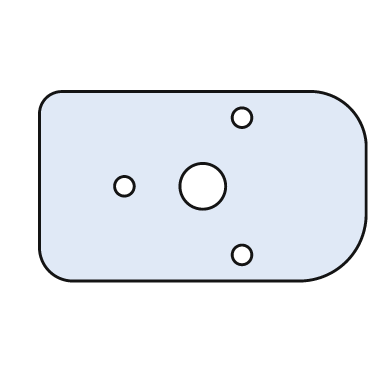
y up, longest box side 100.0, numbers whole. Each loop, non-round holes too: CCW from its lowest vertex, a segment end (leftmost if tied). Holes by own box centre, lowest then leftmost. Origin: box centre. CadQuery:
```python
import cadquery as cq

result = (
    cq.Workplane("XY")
    .moveTo(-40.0, -29.0)
    .lineTo(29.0, -29.0)
    .threePointArc((44.0, -23.0), (50.0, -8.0))
    .lineTo(50.0, 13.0)
    .threePointArc((45.0, 24.0), (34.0, 29.0))
    .lineTo(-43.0, 29.0)
    .threePointArc((-48.0, 27.0), (-50.0, 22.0))
    .lineTo(-50.0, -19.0)
    .threePointArc((-47.0, -26.0), (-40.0, -29.0))
    .close()
    .moveTo(12.0, -21.0)
    .circle(3.0)
    .moveTo(-24.0, 0.0)
    .circle(3.0)
    .moveTo(0.0, 0.0)
    .circle(7.0)
    .moveTo(12.0, 21.0)
    .circle(3.0)
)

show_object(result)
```